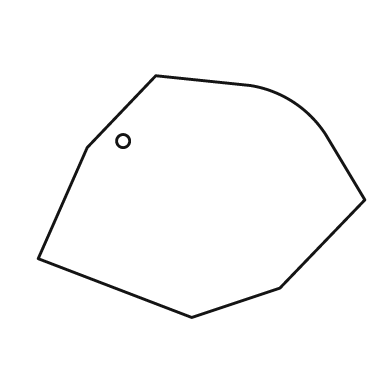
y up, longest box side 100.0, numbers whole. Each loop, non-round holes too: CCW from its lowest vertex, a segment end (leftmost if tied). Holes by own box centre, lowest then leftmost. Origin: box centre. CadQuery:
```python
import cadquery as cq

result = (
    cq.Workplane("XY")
    .moveTo(-3.0, -37.0)
    .lineTo(24.0, -28.0)
    .lineTo(50.0, -1.0)
    .lineTo(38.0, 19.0)
    .threePointArc((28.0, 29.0), (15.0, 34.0))
    .lineTo(-14.0, 37.0)
    .lineTo(-35.0, 15.0)
    .lineTo(-50.0, -19.0)
    .close()
    .moveTo(-24.0, 17.0)
    .circle(2.0)
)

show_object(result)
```